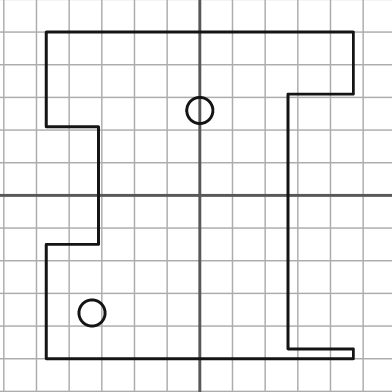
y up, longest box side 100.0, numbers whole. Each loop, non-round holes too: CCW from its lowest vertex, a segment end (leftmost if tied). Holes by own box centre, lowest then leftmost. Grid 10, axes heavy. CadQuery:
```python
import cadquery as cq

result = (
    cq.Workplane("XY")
    .moveTo(-47.0, -50.0)
    .lineTo(47.0, -50.0)
    .lineTo(47.0, -47.0)
    .lineTo(27.0, -47.0)
    .lineTo(27.0, 31.0)
    .lineTo(47.0, 31.0)
    .lineTo(47.0, 50.0)
    .lineTo(-47.0, 50.0)
    .lineTo(-47.0, 21.0)
    .lineTo(-31.0, 21.0)
    .lineTo(-31.0, -15.0)
    .lineTo(-47.0, -15.0)
    .close()
    .moveTo(-33.0, -36.0)
    .circle(4.0)
    .moveTo(0.0, 26.0)
    .circle(4.0)
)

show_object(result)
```